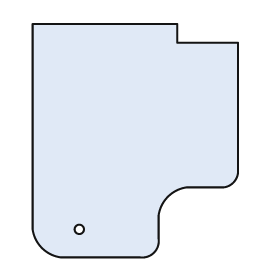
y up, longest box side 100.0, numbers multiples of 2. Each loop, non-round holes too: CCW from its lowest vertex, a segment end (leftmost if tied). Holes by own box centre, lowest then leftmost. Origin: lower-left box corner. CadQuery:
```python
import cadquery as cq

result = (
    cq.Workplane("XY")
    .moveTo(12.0, 0.0)
    .lineTo(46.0, 0.0)
    .threePointArc((52.0, 2.0), (54.0, 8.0))
    .lineTo(54.0, 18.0)
    .threePointArc((58.0, 26.0), (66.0, 30.0))
    .lineTo(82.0, 30.0)
    .threePointArc((86.0, 32.0), (88.0, 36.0))
    .lineTo(88.0, 92.0)
    .lineTo(62.0, 92.0)
    .lineTo(62.0, 100.0)
    .lineTo(0.0, 100.0)
    .lineTo(0.0, 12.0)
    .threePointArc((4.0, 4.0), (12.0, 0.0))
    .close()
    .moveTo(20.0, 12.0)
    .circle(2.0)
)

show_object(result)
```